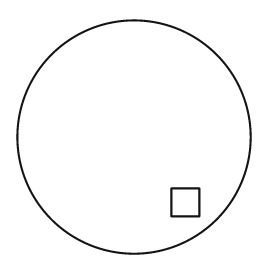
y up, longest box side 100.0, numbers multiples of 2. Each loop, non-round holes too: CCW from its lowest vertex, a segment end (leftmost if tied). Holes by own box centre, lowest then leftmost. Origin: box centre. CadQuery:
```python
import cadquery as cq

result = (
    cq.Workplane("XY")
    .moveTo(0.0, 0.0)
    .circle(50.0)
    .moveTo(16.0, -34.0)
    .lineTo(28.0, -34.0)
    .lineTo(28.0, -22.0)
    .lineTo(16.0, -22.0)
    .close()
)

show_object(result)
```